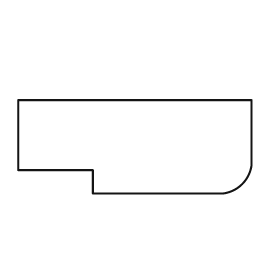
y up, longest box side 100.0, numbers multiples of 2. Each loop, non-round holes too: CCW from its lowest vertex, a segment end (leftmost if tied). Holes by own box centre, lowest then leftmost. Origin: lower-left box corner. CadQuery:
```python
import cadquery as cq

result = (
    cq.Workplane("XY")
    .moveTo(32.0, 0.0)
    .lineTo(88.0, 0.0)
    .threePointArc((96.0, 4.0), (100.0, 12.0))
    .lineTo(100.0, 40.0)
    .lineTo(0.0, 40.0)
    .lineTo(0.0, 10.0)
    .lineTo(32.0, 10.0)
    .close()
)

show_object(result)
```